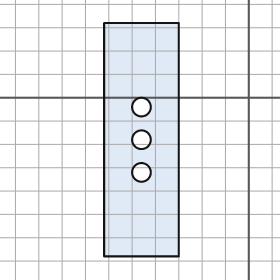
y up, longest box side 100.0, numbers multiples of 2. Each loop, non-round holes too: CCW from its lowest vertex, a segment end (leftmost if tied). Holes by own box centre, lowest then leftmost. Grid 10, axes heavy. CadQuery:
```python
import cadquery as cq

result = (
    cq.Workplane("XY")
    .moveTo(-62.0, -68.0)
    .lineTo(-30.0, -68.0)
    .lineTo(-30.0, 32.0)
    .lineTo(-62.0, 32.0)
    .close()
    .moveTo(-46.0, -32.0)
    .circle(4.0)
    .moveTo(-46.0, -18.0)
    .circle(4.0)
    .moveTo(-46.0, -4.0)
    .circle(4.0)
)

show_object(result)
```